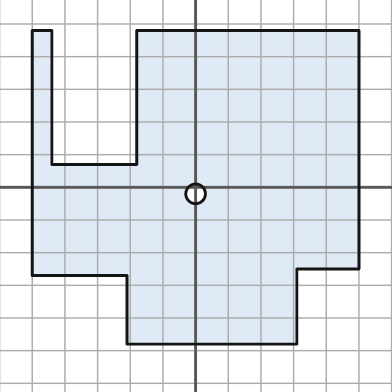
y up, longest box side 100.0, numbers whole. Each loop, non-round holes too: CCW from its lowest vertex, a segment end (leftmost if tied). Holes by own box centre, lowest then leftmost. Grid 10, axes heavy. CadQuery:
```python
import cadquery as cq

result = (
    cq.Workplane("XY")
    .moveTo(-21.0, -48.0)
    .lineTo(31.0, -48.0)
    .lineTo(31.0, -25.0)
    .lineTo(50.0, -25.0)
    .lineTo(50.0, 48.0)
    .lineTo(-18.0, 48.0)
    .lineTo(-18.0, 7.0)
    .lineTo(-44.0, 7.0)
    .lineTo(-44.0, 48.0)
    .lineTo(-50.0, 48.0)
    .lineTo(-50.0, -27.0)
    .lineTo(-21.0, -27.0)
    .close()
    .moveTo(0.0, -2.0)
    .circle(3.0)
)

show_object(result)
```